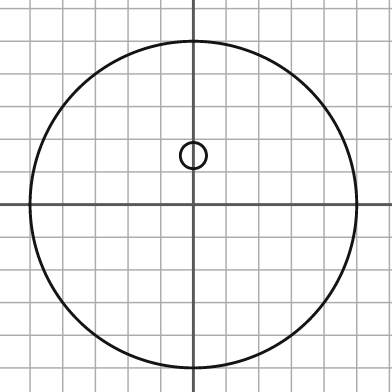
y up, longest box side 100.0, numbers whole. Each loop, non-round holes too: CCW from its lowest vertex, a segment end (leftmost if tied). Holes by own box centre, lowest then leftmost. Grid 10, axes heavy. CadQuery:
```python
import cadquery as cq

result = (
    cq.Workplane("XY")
    .moveTo(0.0, 0.0)
    .circle(50.0)
    .moveTo(0.0, 15.0)
    .circle(4.0)
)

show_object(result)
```